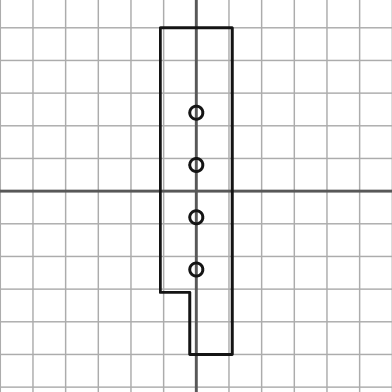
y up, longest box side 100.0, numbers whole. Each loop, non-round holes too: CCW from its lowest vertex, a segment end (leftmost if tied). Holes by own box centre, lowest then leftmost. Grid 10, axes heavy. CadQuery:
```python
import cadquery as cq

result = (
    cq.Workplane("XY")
    .moveTo(-2.0, -50.0)
    .lineTo(11.0, -50.0)
    .lineTo(11.0, 50.0)
    .lineTo(-11.0, 50.0)
    .lineTo(-11.0, -31.0)
    .lineTo(-2.0, -31.0)
    .close()
    .moveTo(0.0, -24.0)
    .circle(2.0)
    .moveTo(0.0, -8.0)
    .circle(2.0)
    .moveTo(0.0, 8.0)
    .circle(2.0)
    .moveTo(0.0, 24.0)
    .circle(2.0)
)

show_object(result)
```